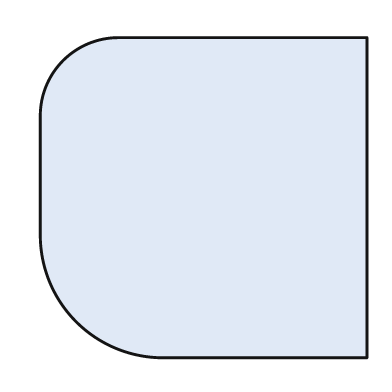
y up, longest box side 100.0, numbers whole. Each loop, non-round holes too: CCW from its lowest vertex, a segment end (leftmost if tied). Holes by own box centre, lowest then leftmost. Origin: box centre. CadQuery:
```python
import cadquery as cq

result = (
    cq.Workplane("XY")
    .moveTo(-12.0, -49.0)
    .lineTo(50.0, -49.0)
    .lineTo(50.0, 49.0)
    .lineTo(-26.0, 49.0)
    .threePointArc((-43.0, 42.0), (-50.0, 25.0))
    .lineTo(-50.0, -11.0)
    .threePointArc((-39.0, -38.0), (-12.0, -49.0))
    .close()
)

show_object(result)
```